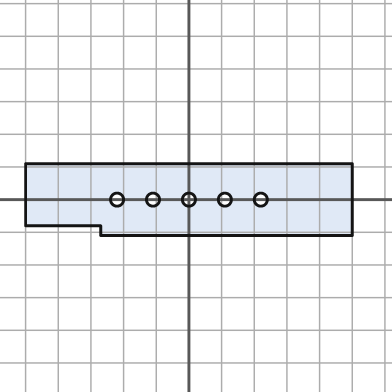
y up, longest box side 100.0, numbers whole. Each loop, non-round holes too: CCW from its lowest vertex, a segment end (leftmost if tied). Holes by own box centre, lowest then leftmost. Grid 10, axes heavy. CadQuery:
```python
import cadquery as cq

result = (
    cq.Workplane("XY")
    .moveTo(-27.0, -11.0)
    .lineTo(50.0, -11.0)
    .lineTo(50.0, 11.0)
    .lineTo(-50.0, 11.0)
    .lineTo(-50.0, -8.0)
    .lineTo(-27.0, -8.0)
    .close()
    .moveTo(-22.0, 0.0)
    .circle(2.0)
    .moveTo(-11.0, 0.0)
    .circle(2.0)
    .moveTo(0.0, 0.0)
    .circle(2.0)
    .moveTo(11.0, 0.0)
    .circle(2.0)
    .moveTo(22.0, 0.0)
    .circle(2.0)
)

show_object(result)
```